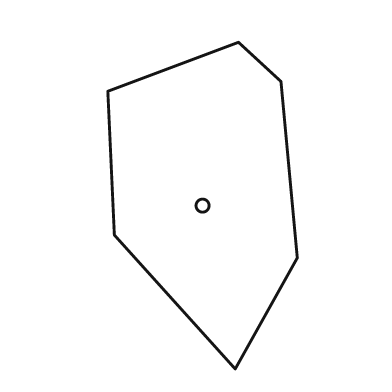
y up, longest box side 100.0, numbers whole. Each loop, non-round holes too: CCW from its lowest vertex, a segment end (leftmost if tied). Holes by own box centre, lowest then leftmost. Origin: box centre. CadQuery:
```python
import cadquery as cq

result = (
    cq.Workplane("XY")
    .moveTo(10.0, -50.0)
    .lineTo(29.0, -16.0)
    .lineTo(24.0, 38.0)
    .lineTo(11.0, 50.0)
    .lineTo(-29.0, 35.0)
    .lineTo(-27.0, -9.0)
    .close()
    .moveTo(0.0, 0.0)
    .circle(2.0)
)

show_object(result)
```